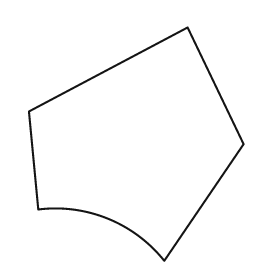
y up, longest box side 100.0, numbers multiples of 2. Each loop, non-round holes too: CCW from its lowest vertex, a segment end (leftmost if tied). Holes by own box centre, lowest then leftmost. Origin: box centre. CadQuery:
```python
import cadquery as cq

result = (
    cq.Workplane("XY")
    .moveTo(12.0, -50.0)
    .lineTo(46.0, 0.0)
    .lineTo(22.0, 50.0)
    .lineTo(-46.0, 14.0)
    .lineTo(-42.0, -28.0)
    .threePointArc((-12.0, -32.0), (12.0, -50.0))
    .close()
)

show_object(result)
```